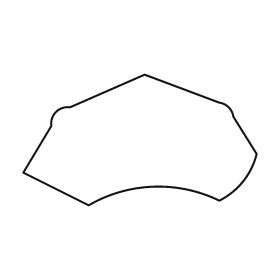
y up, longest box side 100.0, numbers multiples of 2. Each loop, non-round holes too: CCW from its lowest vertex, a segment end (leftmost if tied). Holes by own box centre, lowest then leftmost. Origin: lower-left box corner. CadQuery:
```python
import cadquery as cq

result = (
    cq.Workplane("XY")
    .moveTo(28.0, 0.0)
    .threePointArc((56.0, 8.0), (84.0, 2.0))
    .threePointArc((94.0, 10.0), (100.0, 22.0))
    .lineTo(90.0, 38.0)
    .threePointArc((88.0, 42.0), (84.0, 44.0))
    .lineTo(52.0, 56.0)
    .lineTo(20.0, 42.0)
    .threePointArc((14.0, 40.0), (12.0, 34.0))
    .lineTo(0.0, 14.0)
    .close()
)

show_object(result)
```